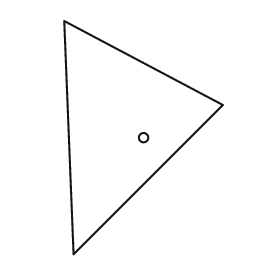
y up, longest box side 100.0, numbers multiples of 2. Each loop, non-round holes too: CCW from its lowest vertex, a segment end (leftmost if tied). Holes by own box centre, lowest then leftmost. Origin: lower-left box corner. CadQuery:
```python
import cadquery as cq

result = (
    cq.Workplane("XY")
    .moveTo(4.0, 0.0)
    .lineTo(68.0, 64.0)
    .lineTo(0.0, 100.0)
    .close()
    .moveTo(34.0, 50.0)
    .circle(2.0)
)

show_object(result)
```